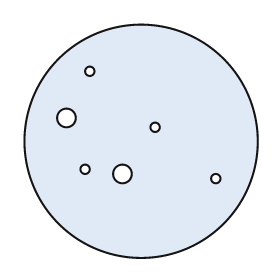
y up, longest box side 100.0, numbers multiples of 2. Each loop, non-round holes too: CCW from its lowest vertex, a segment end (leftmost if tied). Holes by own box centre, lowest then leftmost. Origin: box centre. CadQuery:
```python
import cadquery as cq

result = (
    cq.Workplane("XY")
    .moveTo(0.0, 0.0)
    .circle(50.0)
    .moveTo(32.0, -16.0)
    .circle(2.0)
    .moveTo(-8.0, -14.0)
    .circle(4.0)
    .moveTo(-24.0, -12.0)
    .circle(2.0)
    .moveTo(6.0, 6.0)
    .circle(2.0)
    .moveTo(-32.0, 10.0)
    .circle(4.0)
    .moveTo(-22.0, 30.0)
    .circle(2.0)
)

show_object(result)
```